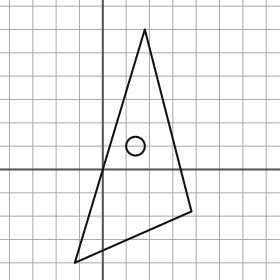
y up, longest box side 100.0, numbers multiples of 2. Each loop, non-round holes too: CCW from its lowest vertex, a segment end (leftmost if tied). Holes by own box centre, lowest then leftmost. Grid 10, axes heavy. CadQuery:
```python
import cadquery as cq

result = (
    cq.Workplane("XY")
    .moveTo(-12.0, -40.0)
    .lineTo(38.0, -18.0)
    .lineTo(18.0, 60.0)
    .close()
    .moveTo(14.0, 10.0)
    .circle(4.0)
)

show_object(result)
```